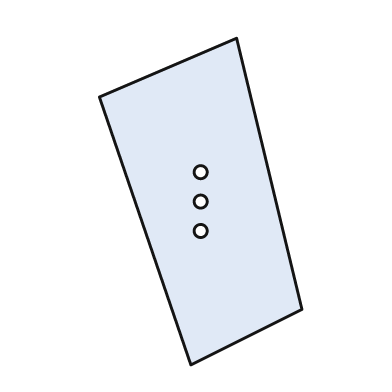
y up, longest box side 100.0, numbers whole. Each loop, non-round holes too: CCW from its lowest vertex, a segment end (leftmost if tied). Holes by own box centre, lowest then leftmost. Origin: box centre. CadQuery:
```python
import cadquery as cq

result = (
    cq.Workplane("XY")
    .moveTo(-3.0, -50.0)
    .lineTo(31.0, -33.0)
    .lineTo(11.0, 50.0)
    .lineTo(-31.0, 32.0)
    .close()
    .moveTo(0.0, -9.0)
    .circle(2.0)
    .moveTo(0.0, 0.0)
    .circle(2.0)
    .moveTo(0.0, 9.0)
    .circle(2.0)
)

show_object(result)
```